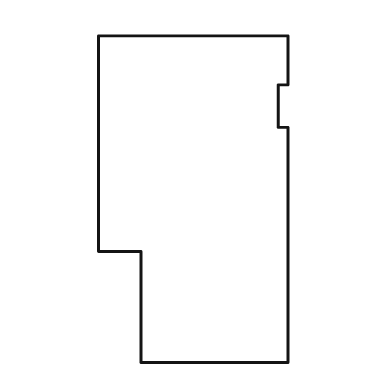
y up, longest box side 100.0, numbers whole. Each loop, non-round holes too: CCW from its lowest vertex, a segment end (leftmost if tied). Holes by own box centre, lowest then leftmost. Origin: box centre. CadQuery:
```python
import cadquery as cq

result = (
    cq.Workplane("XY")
    .moveTo(-16.0, -50.0)
    .lineTo(29.0, -50.0)
    .lineTo(29.0, 22.0)
    .lineTo(26.0, 22.0)
    .lineTo(26.0, 35.0)
    .lineTo(29.0, 35.0)
    .lineTo(29.0, 50.0)
    .lineTo(-29.0, 50.0)
    .lineTo(-29.0, -16.0)
    .lineTo(-16.0, -16.0)
    .close()
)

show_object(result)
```